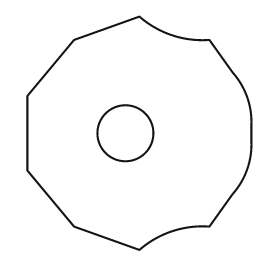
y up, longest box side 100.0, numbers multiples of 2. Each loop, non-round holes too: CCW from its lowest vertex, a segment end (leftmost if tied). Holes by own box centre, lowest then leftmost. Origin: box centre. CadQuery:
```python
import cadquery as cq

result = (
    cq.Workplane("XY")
    .moveTo(0.0, -50.0)
    .threePointArc((14.0, -42.0), (30.0, -40.0))
    .lineTo(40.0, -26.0)
    .threePointArc((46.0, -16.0), (48.0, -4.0))
    .lineTo(48.0, 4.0)
    .threePointArc((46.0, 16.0), (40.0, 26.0))
    .lineTo(30.0, 40.0)
    .threePointArc((14.0, 42.0), (0.0, 50.0))
    .lineTo(-28.0, 40.0)
    .lineTo(-48.0, 16.0)
    .lineTo(-48.0, -16.0)
    .lineTo(-28.0, -40.0)
    .close()
    .moveTo(-6.0, 0.0)
    .circle(12.0)
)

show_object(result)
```